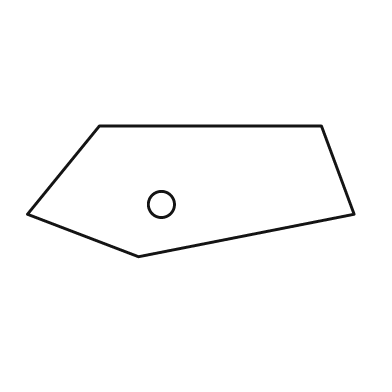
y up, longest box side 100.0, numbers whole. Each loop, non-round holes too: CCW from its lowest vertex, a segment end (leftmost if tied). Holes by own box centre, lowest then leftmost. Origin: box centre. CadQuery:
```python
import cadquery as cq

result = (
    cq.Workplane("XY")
    .moveTo(-16.0, -20.0)
    .lineTo(50.0, -7.0)
    .lineTo(40.0, 20.0)
    .lineTo(-28.0, 20.0)
    .lineTo(-50.0, -7.0)
    .close()
    .moveTo(-9.0, -4.0)
    .circle(4.0)
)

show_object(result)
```